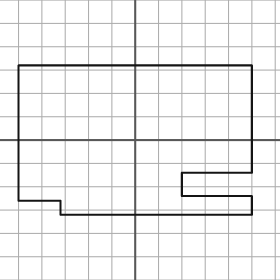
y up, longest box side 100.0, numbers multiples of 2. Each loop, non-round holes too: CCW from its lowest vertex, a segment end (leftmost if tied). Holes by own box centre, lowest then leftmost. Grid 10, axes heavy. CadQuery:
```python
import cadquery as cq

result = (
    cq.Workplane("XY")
    .moveTo(-32.0, -32.0)
    .lineTo(50.0, -32.0)
    .lineTo(50.0, -24.0)
    .lineTo(20.0, -24.0)
    .lineTo(20.0, -14.0)
    .lineTo(50.0, -14.0)
    .lineTo(50.0, 32.0)
    .lineTo(-50.0, 32.0)
    .lineTo(-50.0, -26.0)
    .lineTo(-32.0, -26.0)
    .close()
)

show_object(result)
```